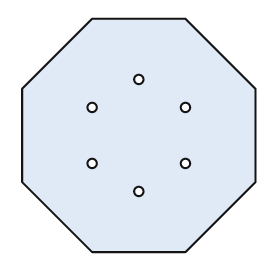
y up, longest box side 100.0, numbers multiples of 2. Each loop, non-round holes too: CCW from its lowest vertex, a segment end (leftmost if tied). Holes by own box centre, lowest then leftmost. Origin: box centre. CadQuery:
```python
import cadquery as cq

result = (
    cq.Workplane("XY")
    .moveTo(-20.0, -50.0)
    .lineTo(20.0, -50.0)
    .lineTo(50.0, -20.0)
    .lineTo(50.0, 20.0)
    .lineTo(20.0, 50.0)
    .lineTo(-20.0, 50.0)
    .lineTo(-50.0, 20.0)
    .lineTo(-50.0, -20.0)
    .close()
    .moveTo(0.0, -24.0)
    .circle(2.0)
    .moveTo(-20.0, -12.0)
    .circle(2.0)
    .moveTo(20.0, -12.0)
    .circle(2.0)
    .moveTo(-20.0, 12.0)
    .circle(2.0)
    .moveTo(20.0, 12.0)
    .circle(2.0)
    .moveTo(0.0, 24.0)
    .circle(2.0)
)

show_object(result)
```